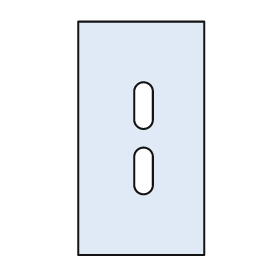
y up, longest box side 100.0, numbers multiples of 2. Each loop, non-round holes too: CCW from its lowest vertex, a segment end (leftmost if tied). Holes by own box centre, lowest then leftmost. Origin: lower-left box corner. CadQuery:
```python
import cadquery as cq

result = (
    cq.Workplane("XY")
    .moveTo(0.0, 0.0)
    .lineTo(54.0, 0.0)
    .lineTo(54.0, 100.0)
    .lineTo(0.0, 100.0)
    .close()
    .moveTo(24.0, 30.0)
    .threePointArc((28.0, 26.0), (32.0, 30.0))
    .lineTo(32.0, 42.0)
    .threePointArc((28.0, 46.0), (24.0, 42.0))
    .close()
    .moveTo(24.0, 58.0)
    .threePointArc((28.0, 54.0), (32.0, 58.0))
    .lineTo(32.0, 70.0)
    .threePointArc((28.0, 74.0), (24.0, 70.0))
    .close()
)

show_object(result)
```